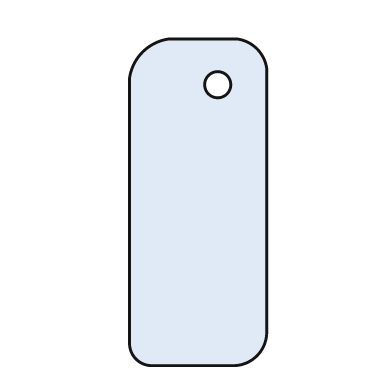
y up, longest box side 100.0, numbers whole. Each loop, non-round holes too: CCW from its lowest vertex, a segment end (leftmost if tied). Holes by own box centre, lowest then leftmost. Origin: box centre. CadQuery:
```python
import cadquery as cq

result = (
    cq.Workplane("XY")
    .moveTo(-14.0, -50.0)
    .lineTo(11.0, -50.0)
    .threePointArc((18.0, -47.0), (21.0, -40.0))
    .lineTo(21.0, 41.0)
    .threePointArc((18.0, 47.0), (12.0, 50.0))
    .lineTo(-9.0, 50.0)
    .threePointArc((-17.0, 46.0), (-21.0, 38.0))
    .lineTo(-21.0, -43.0)
    .threePointArc((-19.0, -48.0), (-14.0, -50.0))
    .close()
    .moveTo(6.0, 36.0)
    .circle(4.0)
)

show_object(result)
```